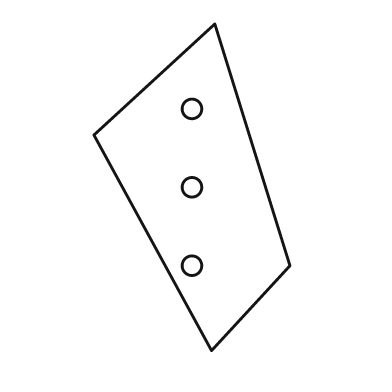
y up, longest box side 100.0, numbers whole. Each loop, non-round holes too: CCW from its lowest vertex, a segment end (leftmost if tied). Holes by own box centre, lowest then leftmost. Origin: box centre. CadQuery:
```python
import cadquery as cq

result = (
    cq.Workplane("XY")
    .moveTo(6.0, -50.0)
    .lineTo(30.0, -24.0)
    .lineTo(7.0, 50.0)
    .lineTo(-30.0, 16.0)
    .close()
    .moveTo(0.0, -24.0)
    .circle(3.0)
    .moveTo(0.0, 0.0)
    .circle(3.0)
    .moveTo(0.0, 24.0)
    .circle(3.0)
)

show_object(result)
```